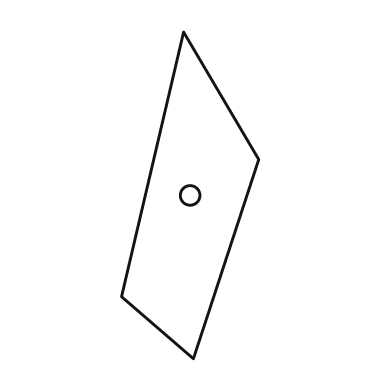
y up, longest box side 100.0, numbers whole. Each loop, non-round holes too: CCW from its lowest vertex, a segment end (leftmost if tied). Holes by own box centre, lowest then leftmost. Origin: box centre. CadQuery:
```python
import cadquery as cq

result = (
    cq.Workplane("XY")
    .moveTo(1.0, -50.0)
    .lineTo(21.0, 11.0)
    .lineTo(-2.0, 50.0)
    .lineTo(-21.0, -31.0)
    .close()
    .moveTo(0.0, 0.0)
    .circle(3.0)
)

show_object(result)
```